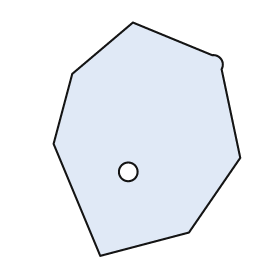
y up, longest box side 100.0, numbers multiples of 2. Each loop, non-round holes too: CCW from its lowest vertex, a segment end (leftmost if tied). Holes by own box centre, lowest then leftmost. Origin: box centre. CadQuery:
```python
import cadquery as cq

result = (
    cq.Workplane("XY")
    .moveTo(-20.0, -50.0)
    .lineTo(18.0, -40.0)
    .lineTo(40.0, -8.0)
    .lineTo(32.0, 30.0)
    .threePointArc((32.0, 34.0), (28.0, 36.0))
    .lineTo(-6.0, 50.0)
    .lineTo(-32.0, 28.0)
    .lineTo(-40.0, -2.0)
    .close()
    .moveTo(-8.0, -14.0)
    .circle(4.0)
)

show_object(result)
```